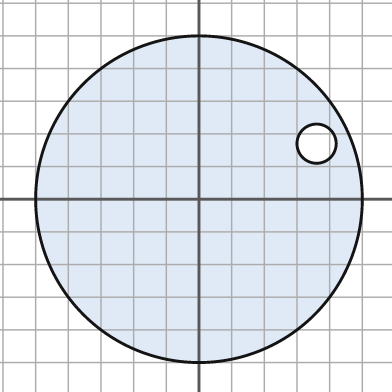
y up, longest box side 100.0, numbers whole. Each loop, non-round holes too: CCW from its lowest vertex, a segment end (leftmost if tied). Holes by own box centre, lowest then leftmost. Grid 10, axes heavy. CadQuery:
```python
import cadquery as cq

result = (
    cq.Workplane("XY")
    .moveTo(0.0, 0.0)
    .circle(50.0)
    .moveTo(36.0, 17.0)
    .circle(6.0)
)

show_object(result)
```